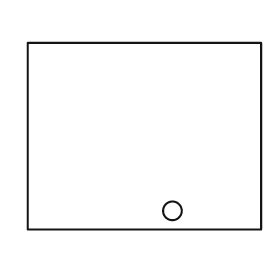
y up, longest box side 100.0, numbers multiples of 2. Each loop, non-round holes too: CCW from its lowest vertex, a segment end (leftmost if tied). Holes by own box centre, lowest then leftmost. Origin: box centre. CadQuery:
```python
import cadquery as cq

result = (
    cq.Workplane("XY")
    .moveTo(-50.0, -40.0)
    .lineTo(50.0, -40.0)
    .lineTo(50.0, 40.0)
    .lineTo(-50.0, 40.0)
    .close()
    .moveTo(12.0, -32.0)
    .circle(4.0)
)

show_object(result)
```